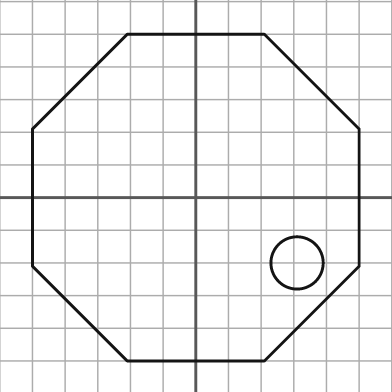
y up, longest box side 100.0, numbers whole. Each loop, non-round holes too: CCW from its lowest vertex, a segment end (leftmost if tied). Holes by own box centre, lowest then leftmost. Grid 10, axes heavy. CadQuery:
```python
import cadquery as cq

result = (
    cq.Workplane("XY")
    .moveTo(-21.0, -50.0)
    .lineTo(21.0, -50.0)
    .lineTo(50.0, -21.0)
    .lineTo(50.0, 21.0)
    .lineTo(21.0, 50.0)
    .lineTo(-21.0, 50.0)
    .lineTo(-50.0, 21.0)
    .lineTo(-50.0, -21.0)
    .close()
    .moveTo(31.0, -20.0)
    .circle(8.0)
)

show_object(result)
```